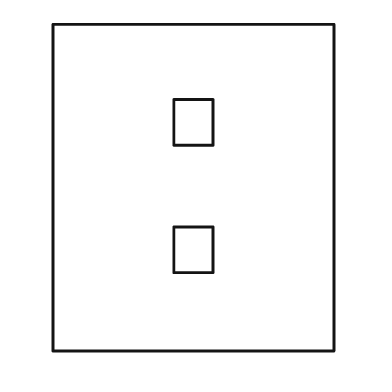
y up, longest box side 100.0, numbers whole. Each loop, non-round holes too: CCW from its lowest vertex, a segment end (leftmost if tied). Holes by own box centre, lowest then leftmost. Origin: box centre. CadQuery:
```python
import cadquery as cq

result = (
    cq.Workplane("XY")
    .moveTo(-43.0, -50.0)
    .lineTo(43.0, -50.0)
    .lineTo(43.0, 50.0)
    .lineTo(-43.0, 50.0)
    .close()
    .moveTo(-6.0, -26.0)
    .lineTo(6.0, -26.0)
    .lineTo(6.0, -12.0)
    .lineTo(-6.0, -12.0)
    .close()
    .moveTo(-6.0, 13.0)
    .lineTo(6.0, 13.0)
    .lineTo(6.0, 27.0)
    .lineTo(-6.0, 27.0)
    .close()
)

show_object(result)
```